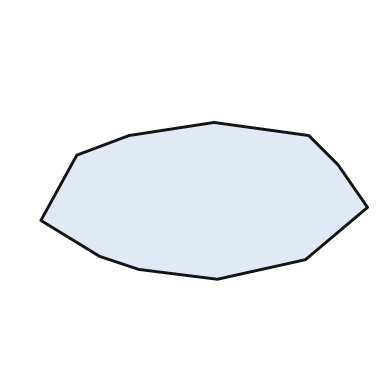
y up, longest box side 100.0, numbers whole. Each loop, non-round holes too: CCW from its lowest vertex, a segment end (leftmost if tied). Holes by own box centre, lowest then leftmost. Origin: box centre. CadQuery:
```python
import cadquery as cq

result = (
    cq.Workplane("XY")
    .moveTo(4.0, -24.0)
    .lineTo(31.0, -18.0)
    .lineTo(50.0, -2.0)
    .lineTo(41.0, 11.0)
    .lineTo(32.0, 20.0)
    .lineTo(3.0, 24.0)
    .lineTo(-23.0, 20.0)
    .lineTo(-39.0, 14.0)
    .lineTo(-50.0, -6.0)
    .lineTo(-32.0, -17.0)
    .lineTo(-20.0, -21.0)
    .close()
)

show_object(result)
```